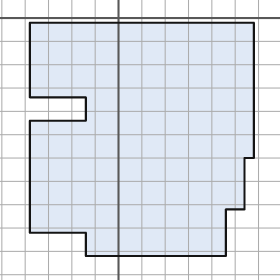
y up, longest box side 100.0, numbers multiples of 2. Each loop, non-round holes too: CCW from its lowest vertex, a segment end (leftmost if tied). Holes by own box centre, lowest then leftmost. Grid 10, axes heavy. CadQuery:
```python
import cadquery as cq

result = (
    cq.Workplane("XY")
    .moveTo(-14.0, -102.0)
    .lineTo(46.0, -102.0)
    .lineTo(46.0, -82.0)
    .lineTo(54.0, -82.0)
    .lineTo(54.0, -60.0)
    .lineTo(58.0, -60.0)
    .lineTo(58.0, -2.0)
    .lineTo(-38.0, -2.0)
    .lineTo(-38.0, -34.0)
    .lineTo(-14.0, -34.0)
    .lineTo(-14.0, -44.0)
    .lineTo(-38.0, -44.0)
    .lineTo(-38.0, -92.0)
    .lineTo(-14.0, -92.0)
    .close()
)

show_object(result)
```